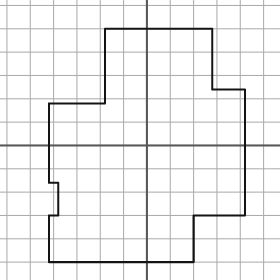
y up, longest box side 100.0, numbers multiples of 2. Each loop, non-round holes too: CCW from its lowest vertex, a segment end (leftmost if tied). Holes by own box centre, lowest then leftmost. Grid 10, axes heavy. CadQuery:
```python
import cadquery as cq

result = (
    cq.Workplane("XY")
    .moveTo(-42.0, -50.0)
    .lineTo(20.0, -50.0)
    .lineTo(20.0, -30.0)
    .lineTo(42.0, -30.0)
    .lineTo(42.0, 24.0)
    .lineTo(28.0, 24.0)
    .lineTo(28.0, 50.0)
    .lineTo(-18.0, 50.0)
    .lineTo(-18.0, 18.0)
    .lineTo(-42.0, 18.0)
    .lineTo(-42.0, -16.0)
    .lineTo(-38.0, -16.0)
    .lineTo(-38.0, -30.0)
    .lineTo(-42.0, -30.0)
    .close()
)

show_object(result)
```